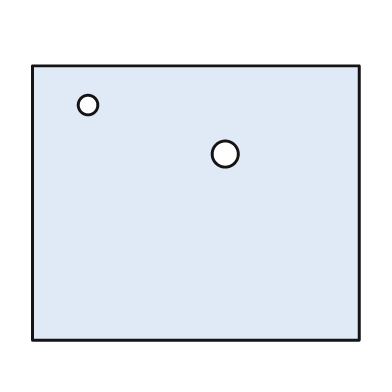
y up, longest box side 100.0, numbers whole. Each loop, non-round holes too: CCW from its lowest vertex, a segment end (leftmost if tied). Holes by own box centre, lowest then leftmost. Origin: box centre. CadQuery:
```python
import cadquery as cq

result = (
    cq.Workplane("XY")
    .moveTo(-50.0, -42.0)
    .lineTo(50.0, -42.0)
    .lineTo(50.0, 42.0)
    .lineTo(-50.0, 42.0)
    .close()
    .moveTo(9.0, 15.0)
    .circle(4.0)
    .moveTo(-33.0, 30.0)
    .circle(3.0)
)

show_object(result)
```